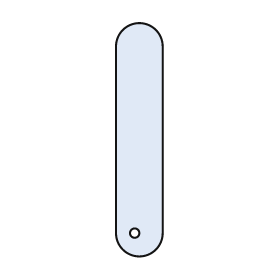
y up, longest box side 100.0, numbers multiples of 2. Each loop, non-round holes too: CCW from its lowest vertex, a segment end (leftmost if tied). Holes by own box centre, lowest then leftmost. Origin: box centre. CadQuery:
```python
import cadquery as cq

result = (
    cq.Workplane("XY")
    .moveTo(-10.0, -40.0)
    .threePointArc((0.0, -50.0), (10.0, -40.0))
    .lineTo(10.0, 40.0)
    .threePointArc((0.0, 50.0), (-10.0, 40.0))
    .close()
    .moveTo(-2.0, -40.0)
    .circle(2.0)
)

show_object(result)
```